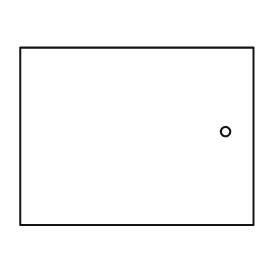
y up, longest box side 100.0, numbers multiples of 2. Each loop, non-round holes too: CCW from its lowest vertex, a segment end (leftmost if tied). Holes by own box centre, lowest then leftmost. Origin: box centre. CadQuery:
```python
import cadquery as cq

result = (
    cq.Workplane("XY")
    .moveTo(-50.0, -38.0)
    .lineTo(50.0, -38.0)
    .lineTo(50.0, 38.0)
    .lineTo(-50.0, 38.0)
    .close()
    .moveTo(38.0, 2.0)
    .circle(2.0)
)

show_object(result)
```